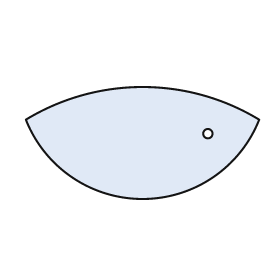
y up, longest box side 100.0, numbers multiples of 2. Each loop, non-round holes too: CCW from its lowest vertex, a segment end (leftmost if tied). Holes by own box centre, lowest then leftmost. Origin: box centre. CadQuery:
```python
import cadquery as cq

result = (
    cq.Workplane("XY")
    .moveTo(-50.0, 10.0)
    .threePointArc((0.0, -24.0), (50.0, 10.0))
    .threePointArc((0.0, 24.0), (-50.0, 10.0))
    .close()
    .moveTo(28.0, 4.0)
    .circle(2.0)
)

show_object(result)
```